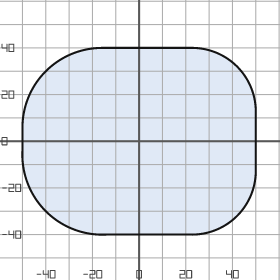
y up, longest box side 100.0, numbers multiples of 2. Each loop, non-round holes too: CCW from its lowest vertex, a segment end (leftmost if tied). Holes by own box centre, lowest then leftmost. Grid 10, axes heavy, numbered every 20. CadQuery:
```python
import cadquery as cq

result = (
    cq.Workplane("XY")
    .moveTo(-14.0, -40.0)
    .lineTo(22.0, -40.0)
    .threePointArc((42.0, -32.0), (50.0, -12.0))
    .lineTo(50.0, 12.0)
    .threePointArc((42.0, 32.0), (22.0, 40.0))
    .lineTo(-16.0, 40.0)
    .threePointArc((-40.0, 30.0), (-50.0, 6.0))
    .lineTo(-50.0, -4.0)
    .threePointArc((-40.0, -30.0), (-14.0, -40.0))
    .close()
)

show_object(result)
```